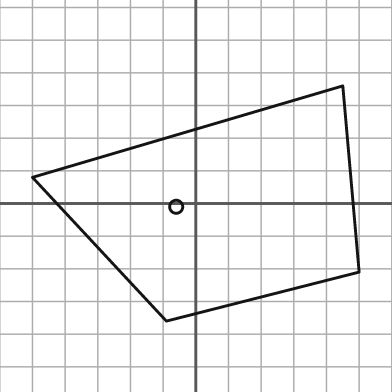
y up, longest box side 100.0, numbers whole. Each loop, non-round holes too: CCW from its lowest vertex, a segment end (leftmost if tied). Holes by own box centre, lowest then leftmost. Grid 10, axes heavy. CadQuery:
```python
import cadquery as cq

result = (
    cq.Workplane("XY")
    .moveTo(-9.0, -36.0)
    .lineTo(50.0, -21.0)
    .lineTo(45.0, 36.0)
    .lineTo(-50.0, 8.0)
    .close()
    .moveTo(-6.0, -1.0)
    .circle(2.0)
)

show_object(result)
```